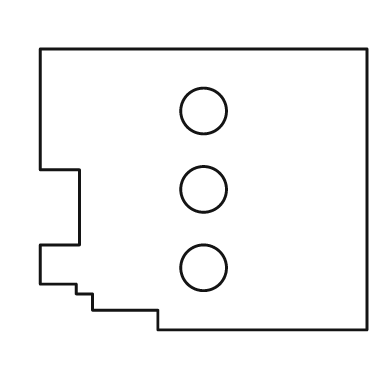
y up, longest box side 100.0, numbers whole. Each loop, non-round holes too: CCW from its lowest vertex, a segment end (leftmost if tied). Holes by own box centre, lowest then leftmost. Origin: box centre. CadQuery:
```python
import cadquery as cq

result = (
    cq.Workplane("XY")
    .moveTo(-14.0, -43.0)
    .lineTo(50.0, -43.0)
    .lineTo(50.0, 43.0)
    .lineTo(-50.0, 43.0)
    .lineTo(-50.0, 6.0)
    .lineTo(-38.0, 6.0)
    .lineTo(-38.0, -17.0)
    .lineTo(-50.0, -17.0)
    .lineTo(-50.0, -29.0)
    .lineTo(-39.0, -29.0)
    .lineTo(-39.0, -32.0)
    .lineTo(-34.0, -32.0)
    .lineTo(-34.0, -37.0)
    .lineTo(-14.0, -37.0)
    .close()
    .moveTo(0.0, -24.0)
    .circle(7.0)
    .moveTo(0.0, 0.0)
    .circle(7.0)
    .moveTo(0.0, 24.0)
    .circle(7.0)
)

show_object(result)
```